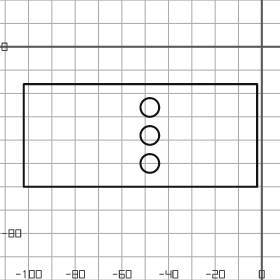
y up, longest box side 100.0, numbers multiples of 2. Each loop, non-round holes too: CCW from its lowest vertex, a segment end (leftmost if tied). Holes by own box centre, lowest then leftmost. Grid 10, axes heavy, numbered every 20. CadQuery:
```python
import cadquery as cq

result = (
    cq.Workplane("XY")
    .moveTo(-102.0, -60.0)
    .lineTo(-2.0, -60.0)
    .lineTo(-2.0, -16.0)
    .lineTo(-102.0, -16.0)
    .close()
    .moveTo(-48.0, -50.0)
    .circle(4.0)
    .moveTo(-48.0, -38.0)
    .circle(4.0)
    .moveTo(-48.0, -26.0)
    .circle(4.0)
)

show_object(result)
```